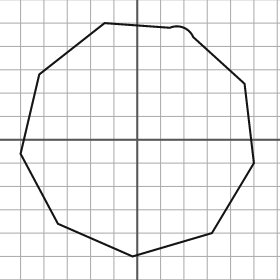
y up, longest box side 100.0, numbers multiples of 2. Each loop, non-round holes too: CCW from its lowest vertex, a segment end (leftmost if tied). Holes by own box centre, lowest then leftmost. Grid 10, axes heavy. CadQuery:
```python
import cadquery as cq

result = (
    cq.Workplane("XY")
    .moveTo(-2.0, -50.0)
    .lineTo(32.0, -40.0)
    .lineTo(50.0, -10.0)
    .lineTo(46.0, 24.0)
    .lineTo(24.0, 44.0)
    .threePointArc((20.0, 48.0), (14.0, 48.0))
    .lineTo(-14.0, 50.0)
    .lineTo(-42.0, 28.0)
    .lineTo(-50.0, -6.0)
    .lineTo(-34.0, -36.0)
    .close()
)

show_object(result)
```